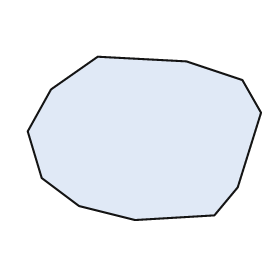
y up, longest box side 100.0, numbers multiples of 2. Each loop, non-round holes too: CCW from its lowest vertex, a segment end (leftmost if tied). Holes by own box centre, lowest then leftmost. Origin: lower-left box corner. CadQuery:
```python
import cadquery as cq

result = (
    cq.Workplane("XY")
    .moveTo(46.0, 0.0)
    .lineTo(80.0, 2.0)
    .lineTo(90.0, 14.0)
    .lineTo(100.0, 46.0)
    .lineTo(92.0, 60.0)
    .lineTo(68.0, 68.0)
    .lineTo(30.0, 70.0)
    .lineTo(10.0, 56.0)
    .lineTo(0.0, 38.0)
    .lineTo(6.0, 18.0)
    .lineTo(22.0, 6.0)
    .close()
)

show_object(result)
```